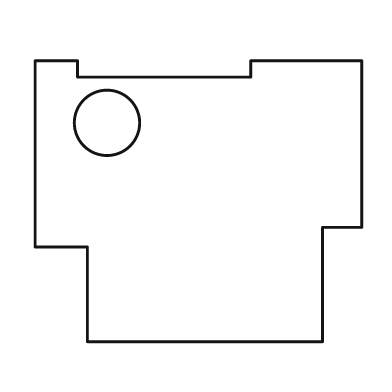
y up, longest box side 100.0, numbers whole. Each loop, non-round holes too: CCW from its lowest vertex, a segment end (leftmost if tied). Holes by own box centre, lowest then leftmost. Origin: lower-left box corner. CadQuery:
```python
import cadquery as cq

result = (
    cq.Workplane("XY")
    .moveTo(16.0, 0.0)
    .lineTo(88.0, 0.0)
    .lineTo(88.0, 35.0)
    .lineTo(100.0, 35.0)
    .lineTo(100.0, 86.0)
    .lineTo(66.0, 86.0)
    .lineTo(66.0, 81.0)
    .lineTo(13.0, 81.0)
    .lineTo(13.0, 86.0)
    .lineTo(0.0, 86.0)
    .lineTo(0.0, 29.0)
    .lineTo(16.0, 29.0)
    .close()
    .moveTo(22.0, 67.0)
    .circle(10.0)
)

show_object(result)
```